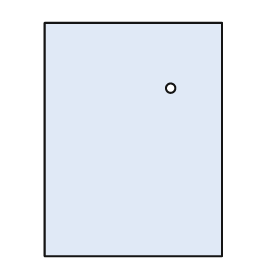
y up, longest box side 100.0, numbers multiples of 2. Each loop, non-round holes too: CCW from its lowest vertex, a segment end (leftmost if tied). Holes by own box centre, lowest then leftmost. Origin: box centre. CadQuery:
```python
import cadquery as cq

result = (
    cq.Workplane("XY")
    .moveTo(-38.0, -50.0)
    .lineTo(38.0, -50.0)
    .lineTo(38.0, 50.0)
    .lineTo(-38.0, 50.0)
    .close()
    .moveTo(16.0, 22.0)
    .circle(2.0)
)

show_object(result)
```